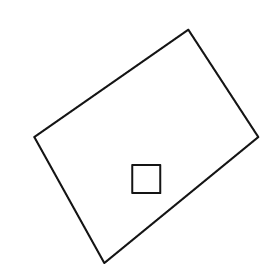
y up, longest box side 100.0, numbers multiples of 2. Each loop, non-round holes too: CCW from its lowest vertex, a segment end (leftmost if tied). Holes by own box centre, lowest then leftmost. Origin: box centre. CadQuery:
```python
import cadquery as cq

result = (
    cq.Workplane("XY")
    .moveTo(-18.0, -50.0)
    .lineTo(48.0, 4.0)
    .lineTo(18.0, 50.0)
    .lineTo(-48.0, 4.0)
    .close()
    .moveTo(-6.0, -20.0)
    .lineTo(6.0, -20.0)
    .lineTo(6.0, -8.0)
    .lineTo(-6.0, -8.0)
    .close()
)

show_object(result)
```